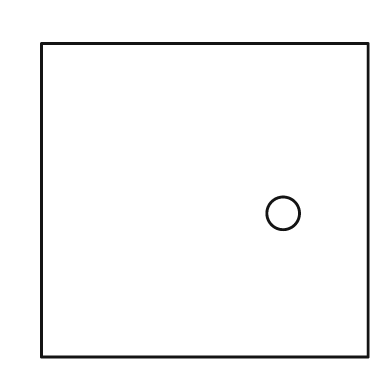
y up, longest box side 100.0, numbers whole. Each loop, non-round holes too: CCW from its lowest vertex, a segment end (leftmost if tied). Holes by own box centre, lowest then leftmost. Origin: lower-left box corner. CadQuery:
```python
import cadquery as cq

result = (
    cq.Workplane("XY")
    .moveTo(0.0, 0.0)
    .lineTo(100.0, 0.0)
    .lineTo(100.0, 96.0)
    .lineTo(0.0, 96.0)
    .close()
    .moveTo(74.0, 44.0)
    .circle(5.0)
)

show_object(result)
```